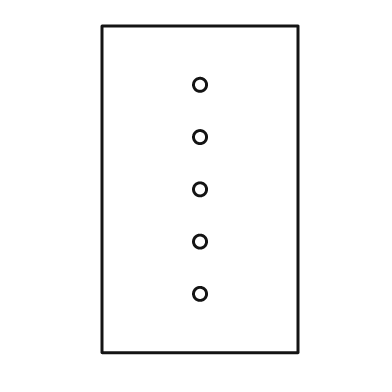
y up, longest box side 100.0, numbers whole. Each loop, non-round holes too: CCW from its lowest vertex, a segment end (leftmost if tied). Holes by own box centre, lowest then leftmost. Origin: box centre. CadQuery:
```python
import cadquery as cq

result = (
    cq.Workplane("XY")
    .moveTo(-30.0, -50.0)
    .lineTo(30.0, -50.0)
    .lineTo(30.0, 50.0)
    .lineTo(-30.0, 50.0)
    .close()
    .moveTo(0.0, -32.0)
    .circle(2.0)
    .moveTo(0.0, -16.0)
    .circle(2.0)
    .moveTo(0.0, 0.0)
    .circle(2.0)
    .moveTo(0.0, 16.0)
    .circle(2.0)
    .moveTo(0.0, 32.0)
    .circle(2.0)
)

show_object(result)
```